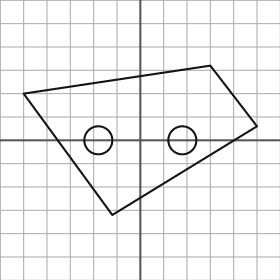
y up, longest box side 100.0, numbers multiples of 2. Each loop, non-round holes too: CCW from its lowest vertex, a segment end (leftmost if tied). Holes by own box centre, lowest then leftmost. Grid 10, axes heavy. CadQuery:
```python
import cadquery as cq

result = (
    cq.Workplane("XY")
    .moveTo(-12.0, -32.0)
    .lineTo(50.0, 6.0)
    .lineTo(30.0, 32.0)
    .lineTo(-50.0, 20.0)
    .close()
    .moveTo(-18.0, 0.0)
    .circle(6.0)
    .moveTo(18.0, 0.0)
    .circle(6.0)
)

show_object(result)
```